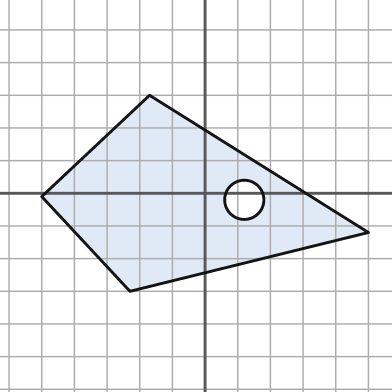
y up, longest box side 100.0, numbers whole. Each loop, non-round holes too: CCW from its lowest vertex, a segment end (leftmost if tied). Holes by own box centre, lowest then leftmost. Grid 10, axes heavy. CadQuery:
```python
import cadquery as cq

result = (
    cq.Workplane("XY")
    .moveTo(-23.0, -30.0)
    .lineTo(50.0, -12.0)
    .lineTo(-17.0, 30.0)
    .lineTo(-50.0, -1.0)
    .close()
    .moveTo(12.0, -2.0)
    .circle(6.0)
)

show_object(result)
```